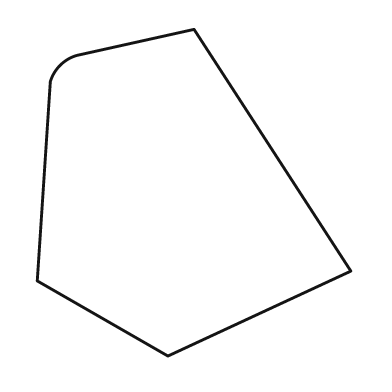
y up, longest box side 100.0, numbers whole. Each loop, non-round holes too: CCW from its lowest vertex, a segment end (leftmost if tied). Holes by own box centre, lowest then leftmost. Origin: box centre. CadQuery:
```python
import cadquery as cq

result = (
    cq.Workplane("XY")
    .moveTo(-8.0, -50.0)
    .lineTo(48.0, -24.0)
    .lineTo(0.0, 50.0)
    .lineTo(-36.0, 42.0)
    .threePointArc((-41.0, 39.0), (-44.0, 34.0))
    .lineTo(-48.0, -27.0)
    .close()
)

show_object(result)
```